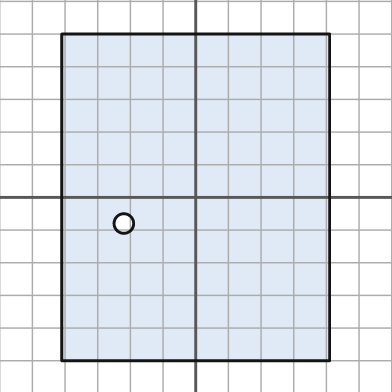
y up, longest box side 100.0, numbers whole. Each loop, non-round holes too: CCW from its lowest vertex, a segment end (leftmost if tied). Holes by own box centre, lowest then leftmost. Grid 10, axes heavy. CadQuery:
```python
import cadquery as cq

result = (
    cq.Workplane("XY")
    .moveTo(-41.0, -50.0)
    .lineTo(41.0, -50.0)
    .lineTo(41.0, 50.0)
    .lineTo(-41.0, 50.0)
    .close()
    .moveTo(-22.0, -8.0)
    .circle(3.0)
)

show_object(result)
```